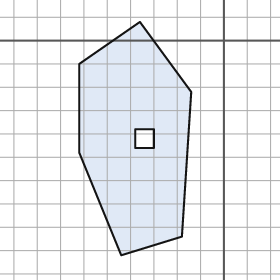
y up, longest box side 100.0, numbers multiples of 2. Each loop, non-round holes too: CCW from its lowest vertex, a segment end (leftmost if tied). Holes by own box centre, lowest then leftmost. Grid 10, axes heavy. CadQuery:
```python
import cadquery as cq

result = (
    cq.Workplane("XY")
    .moveTo(-44.0, -92.0)
    .lineTo(-18.0, -84.0)
    .lineTo(-14.0, -22.0)
    .lineTo(-36.0, 8.0)
    .lineTo(-62.0, -10.0)
    .lineTo(-62.0, -48.0)
    .close()
    .moveTo(-38.0, -46.0)
    .lineTo(-30.0, -46.0)
    .lineTo(-30.0, -38.0)
    .lineTo(-38.0, -38.0)
    .close()
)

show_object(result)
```